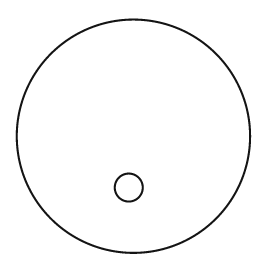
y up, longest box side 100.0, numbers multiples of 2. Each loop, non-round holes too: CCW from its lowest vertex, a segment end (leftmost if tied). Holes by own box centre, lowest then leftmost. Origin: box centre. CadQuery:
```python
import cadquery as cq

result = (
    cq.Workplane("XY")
    .moveTo(0.0, 0.0)
    .circle(50.0)
    .moveTo(-2.0, -22.0)
    .circle(6.0)
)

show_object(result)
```